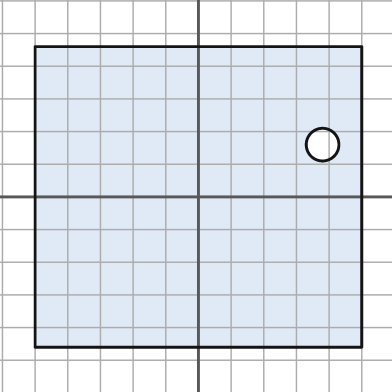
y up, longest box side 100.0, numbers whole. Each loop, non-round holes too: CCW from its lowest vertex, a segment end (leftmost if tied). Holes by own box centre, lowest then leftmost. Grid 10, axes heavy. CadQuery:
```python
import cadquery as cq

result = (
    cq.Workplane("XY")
    .moveTo(-50.0, -46.0)
    .lineTo(50.0, -46.0)
    .lineTo(50.0, 46.0)
    .lineTo(-50.0, 46.0)
    .close()
    .moveTo(38.0, 16.0)
    .circle(5.0)
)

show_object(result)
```